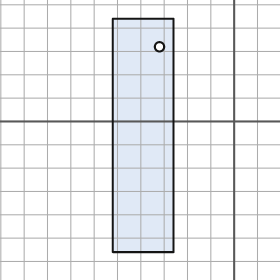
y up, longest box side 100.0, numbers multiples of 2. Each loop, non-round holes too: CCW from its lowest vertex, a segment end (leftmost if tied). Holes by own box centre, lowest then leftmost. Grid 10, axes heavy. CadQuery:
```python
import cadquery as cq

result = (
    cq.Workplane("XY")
    .moveTo(-52.0, -56.0)
    .lineTo(-26.0, -56.0)
    .lineTo(-26.0, 44.0)
    .lineTo(-52.0, 44.0)
    .close()
    .moveTo(-32.0, 32.0)
    .circle(2.0)
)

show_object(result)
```